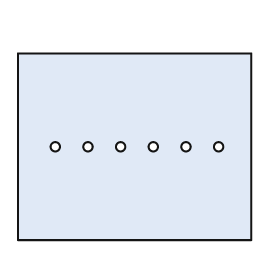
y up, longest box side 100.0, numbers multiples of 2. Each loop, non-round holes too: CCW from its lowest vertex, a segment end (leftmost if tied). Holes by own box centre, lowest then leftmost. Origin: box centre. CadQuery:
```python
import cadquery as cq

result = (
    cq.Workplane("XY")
    .moveTo(-50.0, -40.0)
    .lineTo(50.0, -40.0)
    .lineTo(50.0, 40.0)
    .lineTo(-50.0, 40.0)
    .close()
    .moveTo(-34.0, 0.0)
    .circle(2.0)
    .moveTo(-20.0, 0.0)
    .circle(2.0)
    .moveTo(-6.0, 0.0)
    .circle(2.0)
    .moveTo(8.0, 0.0)
    .circle(2.0)
    .moveTo(22.0, 0.0)
    .circle(2.0)
    .moveTo(36.0, 0.0)
    .circle(2.0)
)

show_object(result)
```